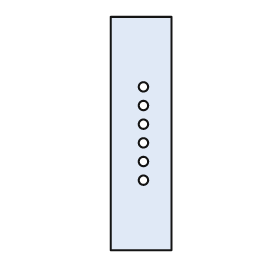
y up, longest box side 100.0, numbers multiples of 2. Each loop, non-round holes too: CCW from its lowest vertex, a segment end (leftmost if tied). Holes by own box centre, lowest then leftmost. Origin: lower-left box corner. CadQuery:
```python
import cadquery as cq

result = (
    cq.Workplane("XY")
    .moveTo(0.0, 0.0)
    .lineTo(26.0, 0.0)
    .lineTo(26.0, 100.0)
    .lineTo(0.0, 100.0)
    .close()
    .moveTo(14.0, 30.0)
    .circle(2.0)
    .moveTo(14.0, 38.0)
    .circle(2.0)
    .moveTo(14.0, 46.0)
    .circle(2.0)
    .moveTo(14.0, 54.0)
    .circle(2.0)
    .moveTo(14.0, 62.0)
    .circle(2.0)
    .moveTo(14.0, 70.0)
    .circle(2.0)
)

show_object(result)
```